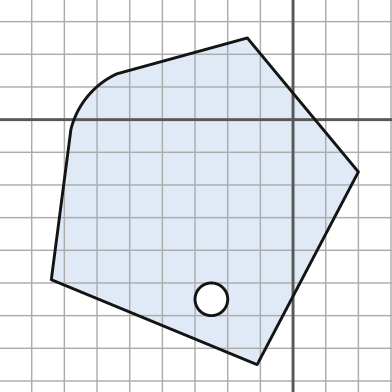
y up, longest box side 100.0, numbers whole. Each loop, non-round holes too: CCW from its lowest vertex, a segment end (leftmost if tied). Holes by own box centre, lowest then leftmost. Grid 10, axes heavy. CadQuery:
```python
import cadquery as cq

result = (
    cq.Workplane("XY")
    .moveTo(-11.0, -75.0)
    .lineTo(20.0, -16.0)
    .lineTo(-14.0, 25.0)
    .lineTo(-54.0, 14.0)
    .threePointArc((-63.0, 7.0), (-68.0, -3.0))
    .lineTo(-74.0, -49.0)
    .close()
    .moveTo(-25.0, -55.0)
    .circle(5.0)
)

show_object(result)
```